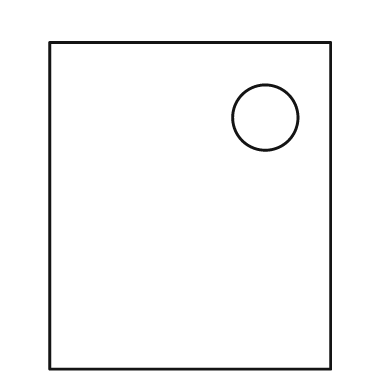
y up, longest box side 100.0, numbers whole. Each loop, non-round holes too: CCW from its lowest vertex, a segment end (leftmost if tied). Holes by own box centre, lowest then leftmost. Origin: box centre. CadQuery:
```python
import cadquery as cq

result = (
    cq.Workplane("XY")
    .moveTo(-43.0, -50.0)
    .lineTo(43.0, -50.0)
    .lineTo(43.0, 50.0)
    .lineTo(-43.0, 50.0)
    .close()
    .moveTo(23.0, 27.0)
    .circle(10.0)
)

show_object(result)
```